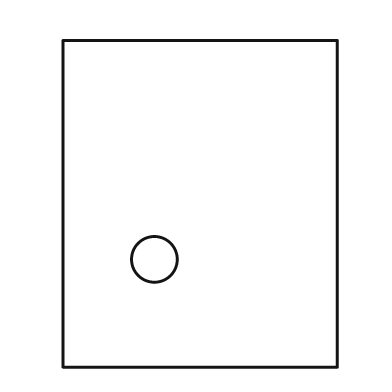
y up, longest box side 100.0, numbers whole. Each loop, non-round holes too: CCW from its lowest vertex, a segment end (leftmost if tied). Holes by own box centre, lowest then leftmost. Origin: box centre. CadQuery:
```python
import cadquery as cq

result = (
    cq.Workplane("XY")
    .moveTo(-42.0, -50.0)
    .lineTo(42.0, -50.0)
    .lineTo(42.0, 50.0)
    .lineTo(-42.0, 50.0)
    .close()
    .moveTo(-14.0, -17.0)
    .circle(7.0)
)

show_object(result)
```